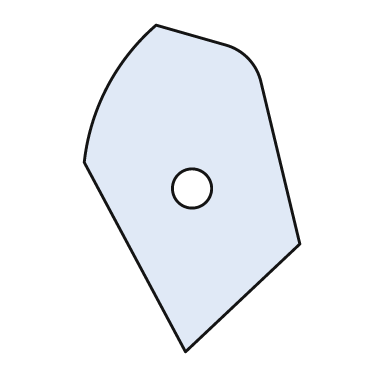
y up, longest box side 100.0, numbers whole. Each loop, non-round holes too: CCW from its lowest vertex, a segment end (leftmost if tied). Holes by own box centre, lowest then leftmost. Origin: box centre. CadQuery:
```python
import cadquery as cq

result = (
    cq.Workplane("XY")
    .moveTo(-2.0, -50.0)
    .lineTo(33.0, -17.0)
    .lineTo(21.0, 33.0)
    .threePointArc((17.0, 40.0), (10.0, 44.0))
    .lineTo(-11.0, 50.0)
    .threePointArc((-26.0, 31.0), (-33.0, 8.0))
    .close()
    .moveTo(0.0, 0.0)
    .circle(6.0)
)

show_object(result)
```